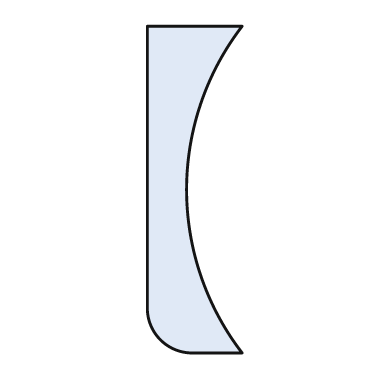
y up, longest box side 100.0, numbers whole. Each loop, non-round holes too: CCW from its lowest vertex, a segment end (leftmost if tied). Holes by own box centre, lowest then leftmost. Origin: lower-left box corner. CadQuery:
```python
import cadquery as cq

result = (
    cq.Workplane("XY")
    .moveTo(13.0, 0.0)
    .lineTo(29.0, 0.0)
    .threePointArc((12.0, 50.0), (29.0, 100.0))
    .lineTo(0.0, 100.0)
    .lineTo(0.0, 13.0)
    .threePointArc((4.0, 4.0), (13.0, 0.0))
    .close()
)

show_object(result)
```